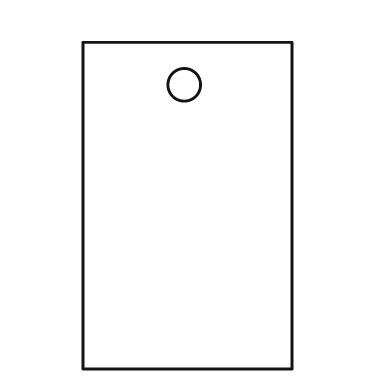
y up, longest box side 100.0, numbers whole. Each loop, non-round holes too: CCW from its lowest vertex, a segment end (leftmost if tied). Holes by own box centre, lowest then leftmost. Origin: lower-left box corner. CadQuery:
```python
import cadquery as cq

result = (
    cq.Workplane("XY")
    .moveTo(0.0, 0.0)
    .lineTo(64.0, 0.0)
    .lineTo(64.0, 100.0)
    .lineTo(0.0, 100.0)
    .close()
    .moveTo(31.0, 87.0)
    .circle(5.0)
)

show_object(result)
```